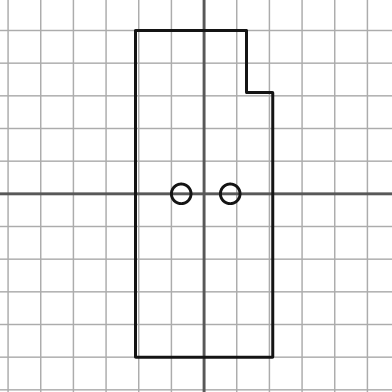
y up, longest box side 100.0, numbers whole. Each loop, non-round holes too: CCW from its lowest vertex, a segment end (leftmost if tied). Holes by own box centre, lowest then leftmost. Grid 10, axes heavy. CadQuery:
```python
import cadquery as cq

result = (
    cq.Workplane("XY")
    .moveTo(-21.0, -50.0)
    .lineTo(21.0, -50.0)
    .lineTo(21.0, 31.0)
    .lineTo(13.0, 31.0)
    .lineTo(13.0, 50.0)
    .lineTo(-21.0, 50.0)
    .close()
    .moveTo(-7.0, 0.0)
    .circle(3.0)
    .moveTo(8.0, 0.0)
    .circle(3.0)
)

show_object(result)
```